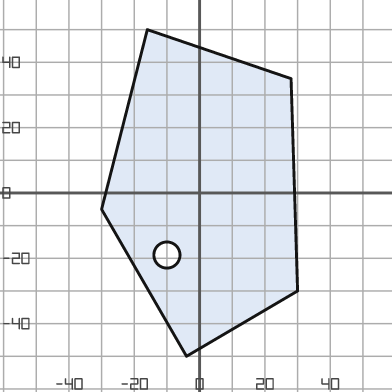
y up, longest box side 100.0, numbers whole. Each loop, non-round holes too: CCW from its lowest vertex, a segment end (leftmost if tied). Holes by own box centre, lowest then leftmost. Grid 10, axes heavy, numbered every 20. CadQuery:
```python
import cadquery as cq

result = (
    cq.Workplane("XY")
    .moveTo(-4.0, -50.0)
    .lineTo(30.0, -30.0)
    .lineTo(28.0, 35.0)
    .lineTo(-16.0, 50.0)
    .lineTo(-30.0, -5.0)
    .close()
    .moveTo(-10.0, -19.0)
    .circle(4.0)
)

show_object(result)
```